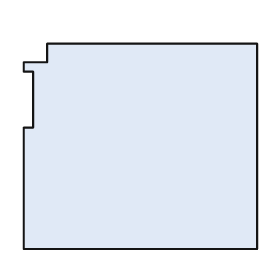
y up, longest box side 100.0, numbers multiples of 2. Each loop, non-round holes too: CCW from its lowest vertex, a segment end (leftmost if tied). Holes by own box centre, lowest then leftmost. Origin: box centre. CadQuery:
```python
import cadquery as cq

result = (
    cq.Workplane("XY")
    .moveTo(-50.0, -44.0)
    .lineTo(50.0, -44.0)
    .lineTo(50.0, 44.0)
    .lineTo(-40.0, 44.0)
    .lineTo(-40.0, 36.0)
    .lineTo(-50.0, 36.0)
    .lineTo(-50.0, 32.0)
    .lineTo(-46.0, 32.0)
    .lineTo(-46.0, 8.0)
    .lineTo(-50.0, 8.0)
    .close()
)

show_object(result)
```